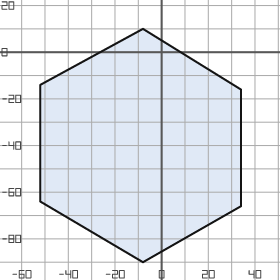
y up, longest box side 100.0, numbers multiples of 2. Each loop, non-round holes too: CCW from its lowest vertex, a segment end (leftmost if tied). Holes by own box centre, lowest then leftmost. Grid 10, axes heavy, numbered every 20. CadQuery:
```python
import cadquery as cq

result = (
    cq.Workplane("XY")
    .moveTo(-8.0, -90.0)
    .lineTo(34.0, -66.0)
    .lineTo(34.0, -16.0)
    .lineTo(-8.0, 10.0)
    .lineTo(-52.0, -14.0)
    .lineTo(-52.0, -64.0)
    .close()
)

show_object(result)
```